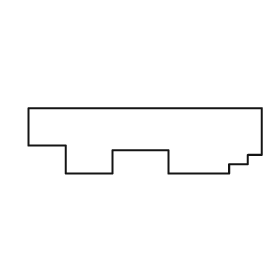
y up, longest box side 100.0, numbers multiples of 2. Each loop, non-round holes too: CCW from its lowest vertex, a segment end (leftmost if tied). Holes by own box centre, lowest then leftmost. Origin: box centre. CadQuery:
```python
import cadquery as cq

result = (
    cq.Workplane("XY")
    .moveTo(-34.0, -14.0)
    .lineTo(-14.0, -14.0)
    .lineTo(-14.0, -4.0)
    .lineTo(10.0, -4.0)
    .lineTo(10.0, -14.0)
    .lineTo(36.0, -14.0)
    .lineTo(36.0, -10.0)
    .lineTo(44.0, -10.0)
    .lineTo(44.0, -6.0)
    .lineTo(50.0, -6.0)
    .lineTo(50.0, 14.0)
    .lineTo(-50.0, 14.0)
    .lineTo(-50.0, -2.0)
    .lineTo(-34.0, -2.0)
    .close()
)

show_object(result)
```